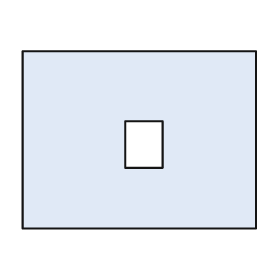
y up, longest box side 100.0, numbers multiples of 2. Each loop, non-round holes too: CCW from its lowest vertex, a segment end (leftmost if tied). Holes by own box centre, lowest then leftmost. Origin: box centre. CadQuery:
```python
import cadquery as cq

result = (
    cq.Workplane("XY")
    .moveTo(-50.0, -38.0)
    .lineTo(50.0, -38.0)
    .lineTo(50.0, 38.0)
    .lineTo(-50.0, 38.0)
    .close()
    .moveTo(-6.0, -12.0)
    .lineTo(10.0, -12.0)
    .lineTo(10.0, 8.0)
    .lineTo(-6.0, 8.0)
    .close()
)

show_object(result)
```